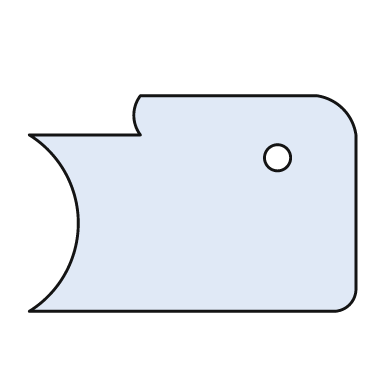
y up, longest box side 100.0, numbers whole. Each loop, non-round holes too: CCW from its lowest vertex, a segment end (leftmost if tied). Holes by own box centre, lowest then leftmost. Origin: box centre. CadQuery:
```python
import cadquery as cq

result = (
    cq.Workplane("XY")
    .moveTo(-50.0, -33.0)
    .lineTo(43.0, -33.0)
    .threePointArc((48.0, -31.0), (50.0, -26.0))
    .lineTo(50.0, 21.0)
    .threePointArc((46.0, 29.0), (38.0, 33.0))
    .lineTo(-16.0, 33.0)
    .threePointArc((-18.0, 27.0), (-16.0, 21.0))
    .lineTo(-50.0, 21.0)
    .threePointArc((-35.0, -6.0), (-50.0, -33.0))
    .close()
    .moveTo(26.0, 14.0)
    .circle(4.0)
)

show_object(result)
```